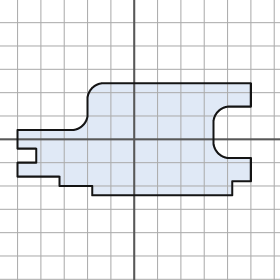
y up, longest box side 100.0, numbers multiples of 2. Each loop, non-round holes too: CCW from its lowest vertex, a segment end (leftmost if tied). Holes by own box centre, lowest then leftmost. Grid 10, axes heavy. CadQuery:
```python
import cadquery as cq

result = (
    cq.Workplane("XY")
    .moveTo(-18.0, -24.0)
    .lineTo(42.0, -24.0)
    .lineTo(42.0, -18.0)
    .lineTo(50.0, -18.0)
    .lineTo(50.0, -8.0)
    .lineTo(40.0, -8.0)
    .threePointArc((36.0, -6.0), (34.0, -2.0))
    .lineTo(34.0, 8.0)
    .threePointArc((36.0, 12.0), (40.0, 14.0))
    .lineTo(50.0, 14.0)
    .lineTo(50.0, 24.0)
    .lineTo(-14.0, 24.0)
    .threePointArc((-18.0, 22.0), (-20.0, 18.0))
    .lineTo(-20.0, 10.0)
    .threePointArc((-22.0, 6.0), (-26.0, 4.0))
    .lineTo(-50.0, 4.0)
    .lineTo(-50.0, -4.0)
    .lineTo(-42.0, -4.0)
    .lineTo(-42.0, -10.0)
    .lineTo(-50.0, -10.0)
    .lineTo(-50.0, -16.0)
    .lineTo(-32.0, -16.0)
    .lineTo(-32.0, -20.0)
    .lineTo(-18.0, -20.0)
    .close()
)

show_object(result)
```